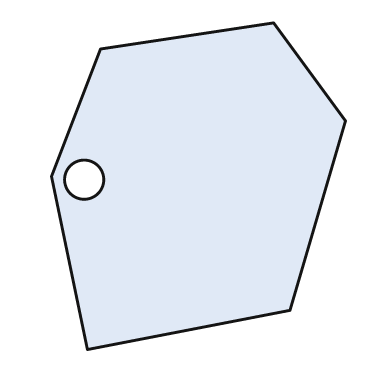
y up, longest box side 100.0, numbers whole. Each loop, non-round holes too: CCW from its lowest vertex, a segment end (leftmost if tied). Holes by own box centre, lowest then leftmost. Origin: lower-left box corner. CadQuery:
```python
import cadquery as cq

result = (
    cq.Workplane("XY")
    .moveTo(11.0, 0.0)
    .lineTo(73.0, 12.0)
    .lineTo(90.0, 70.0)
    .lineTo(68.0, 100.0)
    .lineTo(15.0, 92.0)
    .lineTo(0.0, 53.0)
    .close()
    .moveTo(10.0, 52.0)
    .circle(6.0)
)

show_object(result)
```